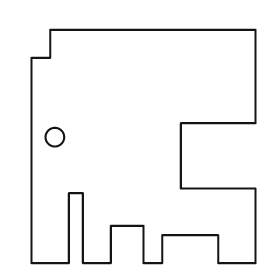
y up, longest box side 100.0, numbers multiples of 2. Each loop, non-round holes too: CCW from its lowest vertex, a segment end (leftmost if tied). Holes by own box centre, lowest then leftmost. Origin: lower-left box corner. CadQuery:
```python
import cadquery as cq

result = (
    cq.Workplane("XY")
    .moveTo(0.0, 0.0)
    .lineTo(16.0, 0.0)
    .lineTo(16.0, 30.0)
    .lineTo(22.0, 30.0)
    .lineTo(22.0, 0.0)
    .lineTo(34.0, 0.0)
    .lineTo(34.0, 16.0)
    .lineTo(48.0, 16.0)
    .lineTo(48.0, 0.0)
    .lineTo(56.0, 0.0)
    .lineTo(56.0, 12.0)
    .lineTo(80.0, 12.0)
    .lineTo(80.0, 0.0)
    .lineTo(96.0, 0.0)
    .lineTo(96.0, 32.0)
    .lineTo(64.0, 32.0)
    .lineTo(64.0, 60.0)
    .lineTo(96.0, 60.0)
    .lineTo(96.0, 100.0)
    .lineTo(8.0, 100.0)
    .lineTo(8.0, 88.0)
    .lineTo(0.0, 88.0)
    .close()
    .moveTo(10.0, 54.0)
    .circle(4.0)
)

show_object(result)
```